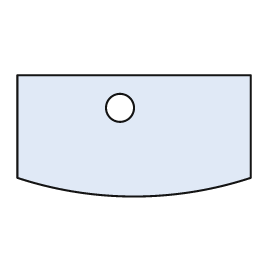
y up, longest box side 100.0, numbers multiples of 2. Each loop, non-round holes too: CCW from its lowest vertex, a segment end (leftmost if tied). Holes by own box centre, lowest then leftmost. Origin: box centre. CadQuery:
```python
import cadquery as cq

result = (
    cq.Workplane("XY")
    .moveTo(-50.0, -18.0)
    .threePointArc((0.0, -26.0), (50.0, -18.0))
    .lineTo(50.0, 26.0)
    .lineTo(-50.0, 26.0)
    .close()
    .moveTo(-6.0, 12.0)
    .circle(6.0)
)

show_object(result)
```